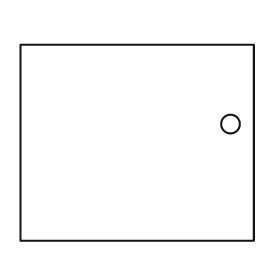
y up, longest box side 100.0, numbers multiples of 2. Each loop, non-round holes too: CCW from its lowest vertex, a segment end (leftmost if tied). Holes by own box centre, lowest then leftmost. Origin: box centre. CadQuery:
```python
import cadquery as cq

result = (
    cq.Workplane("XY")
    .moveTo(-50.0, -42.0)
    .lineTo(50.0, -42.0)
    .lineTo(50.0, 42.0)
    .lineTo(-50.0, 42.0)
    .close()
    .moveTo(40.0, 8.0)
    .circle(4.0)
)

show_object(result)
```